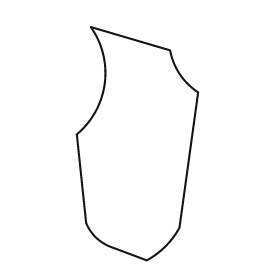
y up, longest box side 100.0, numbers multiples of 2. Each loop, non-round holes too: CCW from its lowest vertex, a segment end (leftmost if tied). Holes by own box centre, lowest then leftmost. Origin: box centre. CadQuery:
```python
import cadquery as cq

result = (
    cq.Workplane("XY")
    .moveTo(4.0, -50.0)
    .threePointArc((12.0, -44.0), (18.0, -36.0))
    .lineTo(26.0, 22.0)
    .threePointArc((18.0, 30.0), (14.0, 40.0))
    .lineTo(-20.0, 50.0)
    .threePointArc((-14.0, 26.0), (-26.0, 4.0))
    .lineTo(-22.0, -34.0)
    .threePointArc((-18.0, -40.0), (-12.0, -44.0))
    .close()
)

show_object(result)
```